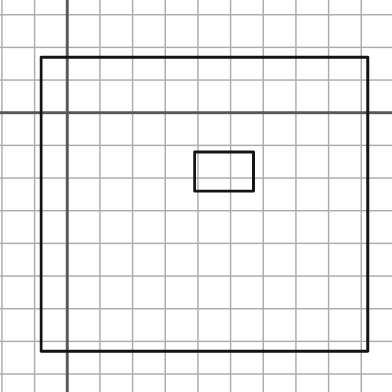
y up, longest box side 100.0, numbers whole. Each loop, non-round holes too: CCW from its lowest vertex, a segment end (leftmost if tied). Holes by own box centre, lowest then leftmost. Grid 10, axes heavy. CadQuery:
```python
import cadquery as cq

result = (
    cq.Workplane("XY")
    .moveTo(-8.0, -73.0)
    .lineTo(92.0, -73.0)
    .lineTo(92.0, 17.0)
    .lineTo(-8.0, 17.0)
    .close()
    .moveTo(39.0, -24.0)
    .lineTo(57.0, -24.0)
    .lineTo(57.0, -12.0)
    .lineTo(39.0, -12.0)
    .close()
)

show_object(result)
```